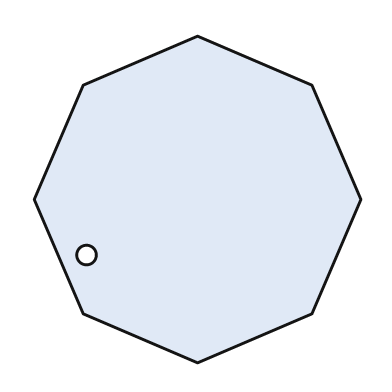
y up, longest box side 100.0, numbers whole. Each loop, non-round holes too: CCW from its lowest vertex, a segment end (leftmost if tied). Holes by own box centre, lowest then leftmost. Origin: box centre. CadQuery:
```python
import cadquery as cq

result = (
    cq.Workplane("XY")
    .moveTo(0.0, -50.0)
    .lineTo(35.0, -35.0)
    .lineTo(50.0, 0.0)
    .lineTo(35.0, 35.0)
    .lineTo(0.0, 50.0)
    .lineTo(-35.0, 35.0)
    .lineTo(-50.0, 0.0)
    .lineTo(-35.0, -35.0)
    .close()
    .moveTo(-34.0, -17.0)
    .circle(3.0)
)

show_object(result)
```